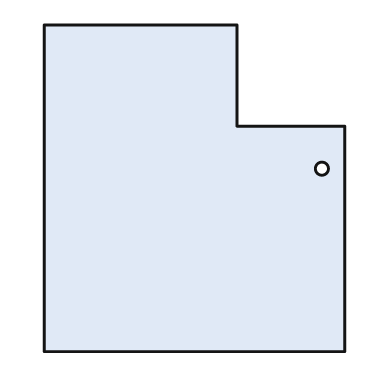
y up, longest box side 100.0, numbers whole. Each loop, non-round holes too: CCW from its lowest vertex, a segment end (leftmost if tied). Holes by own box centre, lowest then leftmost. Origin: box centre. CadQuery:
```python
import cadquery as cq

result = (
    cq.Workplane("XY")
    .moveTo(-46.0, -50.0)
    .lineTo(46.0, -50.0)
    .lineTo(46.0, 19.0)
    .lineTo(13.0, 19.0)
    .lineTo(13.0, 50.0)
    .lineTo(-46.0, 50.0)
    .close()
    .moveTo(39.0, 6.0)
    .circle(2.0)
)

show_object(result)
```